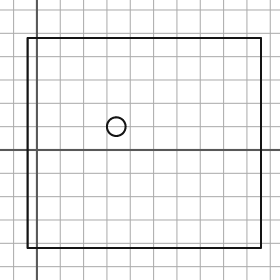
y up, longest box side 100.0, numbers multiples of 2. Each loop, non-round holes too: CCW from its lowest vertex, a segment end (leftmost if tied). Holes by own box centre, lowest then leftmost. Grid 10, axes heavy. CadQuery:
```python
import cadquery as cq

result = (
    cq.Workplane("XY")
    .moveTo(-4.0, -42.0)
    .lineTo(96.0, -42.0)
    .lineTo(96.0, 48.0)
    .lineTo(-4.0, 48.0)
    .close()
    .moveTo(34.0, 10.0)
    .circle(4.0)
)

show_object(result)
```